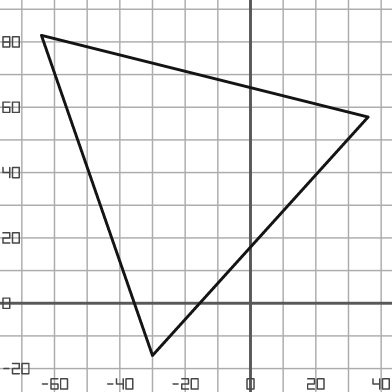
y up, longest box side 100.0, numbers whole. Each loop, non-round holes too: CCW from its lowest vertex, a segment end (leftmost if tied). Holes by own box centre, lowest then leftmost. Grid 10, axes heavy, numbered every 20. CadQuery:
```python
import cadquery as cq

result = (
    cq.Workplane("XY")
    .moveTo(-30.0, -16.0)
    .lineTo(36.0, 57.0)
    .lineTo(-64.0, 82.0)
    .close()
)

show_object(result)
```